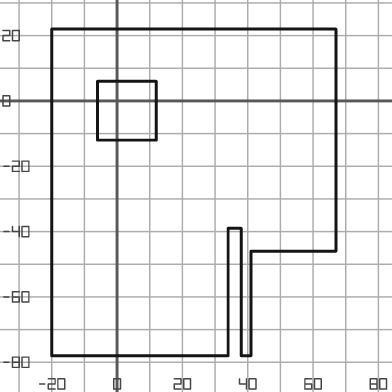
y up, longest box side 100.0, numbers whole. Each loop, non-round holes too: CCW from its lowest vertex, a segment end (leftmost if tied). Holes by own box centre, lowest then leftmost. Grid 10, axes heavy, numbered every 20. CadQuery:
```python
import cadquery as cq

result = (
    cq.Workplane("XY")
    .moveTo(-20.0, -78.0)
    .lineTo(34.0, -78.0)
    .lineTo(34.0, -39.0)
    .lineTo(38.0, -39.0)
    .lineTo(38.0, -78.0)
    .lineTo(41.0, -78.0)
    .lineTo(41.0, -46.0)
    .lineTo(67.0, -46.0)
    .lineTo(67.0, 22.0)
    .lineTo(-20.0, 22.0)
    .close()
    .moveTo(-6.0, -12.0)
    .lineTo(12.0, -12.0)
    .lineTo(12.0, 6.0)
    .lineTo(-6.0, 6.0)
    .close()
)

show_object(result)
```